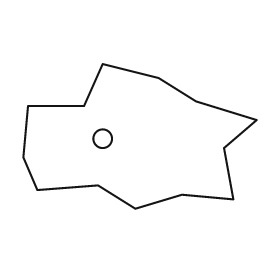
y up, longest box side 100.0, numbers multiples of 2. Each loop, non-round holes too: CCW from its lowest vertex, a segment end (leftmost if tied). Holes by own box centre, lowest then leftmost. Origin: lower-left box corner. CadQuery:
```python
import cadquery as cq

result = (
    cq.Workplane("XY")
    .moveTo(48.0, 0.0)
    .lineTo(68.0, 6.0)
    .lineTo(90.0, 4.0)
    .lineTo(86.0, 26.0)
    .lineTo(100.0, 38.0)
    .lineTo(74.0, 46.0)
    .lineTo(58.0, 56.0)
    .lineTo(34.0, 62.0)
    .lineTo(26.0, 44.0)
    .lineTo(2.0, 44.0)
    .lineTo(0.0, 22.0)
    .lineTo(6.0, 8.0)
    .lineTo(32.0, 10.0)
    .close()
    .moveTo(34.0, 30.0)
    .circle(4.0)
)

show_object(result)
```